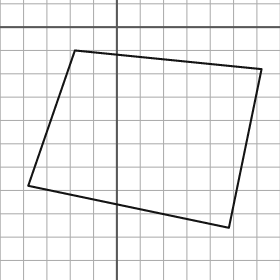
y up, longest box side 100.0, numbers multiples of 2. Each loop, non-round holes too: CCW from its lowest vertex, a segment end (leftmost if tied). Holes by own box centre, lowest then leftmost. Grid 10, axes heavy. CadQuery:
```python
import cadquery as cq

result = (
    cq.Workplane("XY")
    .moveTo(48.0, -86.0)
    .lineTo(62.0, -18.0)
    .lineTo(-18.0, -10.0)
    .lineTo(-38.0, -68.0)
    .close()
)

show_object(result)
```